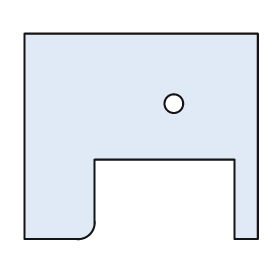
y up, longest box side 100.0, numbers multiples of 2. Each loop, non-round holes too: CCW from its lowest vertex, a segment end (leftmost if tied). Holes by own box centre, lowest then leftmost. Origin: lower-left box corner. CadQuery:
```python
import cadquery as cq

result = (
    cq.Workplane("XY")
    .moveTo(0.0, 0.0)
    .lineTo(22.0, 0.0)
    .threePointArc((28.0, 2.0), (30.0, 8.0))
    .lineTo(30.0, 34.0)
    .lineTo(90.0, 34.0)
    .lineTo(90.0, 0.0)
    .lineTo(100.0, 0.0)
    .lineTo(100.0, 88.0)
    .lineTo(0.0, 88.0)
    .close()
    .moveTo(64.0, 58.0)
    .circle(4.0)
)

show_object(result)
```